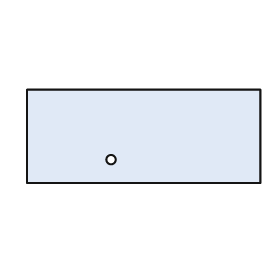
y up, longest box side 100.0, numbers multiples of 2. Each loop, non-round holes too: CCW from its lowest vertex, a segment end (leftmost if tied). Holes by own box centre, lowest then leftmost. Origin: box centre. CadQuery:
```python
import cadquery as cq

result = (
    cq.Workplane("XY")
    .moveTo(-50.0, -20.0)
    .lineTo(50.0, -20.0)
    .lineTo(50.0, 20.0)
    .lineTo(-50.0, 20.0)
    .close()
    .moveTo(-14.0, -10.0)
    .circle(2.0)
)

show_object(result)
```